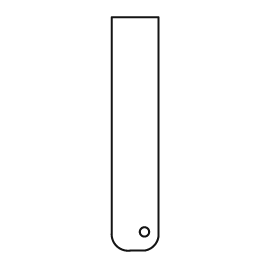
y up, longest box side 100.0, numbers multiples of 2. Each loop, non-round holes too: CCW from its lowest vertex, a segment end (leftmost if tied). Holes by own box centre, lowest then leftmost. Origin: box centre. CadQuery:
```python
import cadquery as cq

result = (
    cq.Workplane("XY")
    .moveTo(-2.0, -50.0)
    .lineTo(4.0, -50.0)
    .threePointArc((8.0, -48.0), (10.0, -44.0))
    .lineTo(10.0, 50.0)
    .lineTo(-10.0, 50.0)
    .lineTo(-10.0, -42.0)
    .threePointArc((-8.0, -48.0), (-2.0, -50.0))
    .close()
    .moveTo(4.0, -42.0)
    .circle(2.0)
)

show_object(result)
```